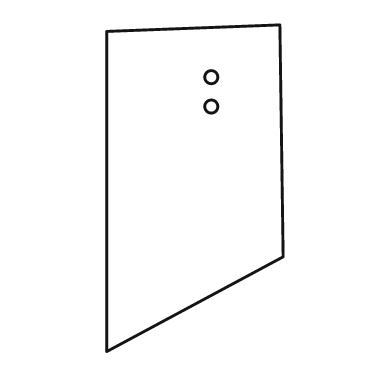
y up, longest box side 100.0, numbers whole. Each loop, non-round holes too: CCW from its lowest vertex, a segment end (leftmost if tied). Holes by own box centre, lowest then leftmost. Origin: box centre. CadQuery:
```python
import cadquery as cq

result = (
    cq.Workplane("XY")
    .moveTo(-27.0, -50.0)
    .lineTo(27.0, -21.0)
    .lineTo(26.0, 50.0)
    .lineTo(-27.0, 48.0)
    .close()
    .moveTo(5.0, 25.0)
    .circle(2.0)
    .moveTo(5.0, 34.0)
    .circle(2.0)
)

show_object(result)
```